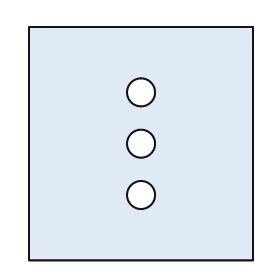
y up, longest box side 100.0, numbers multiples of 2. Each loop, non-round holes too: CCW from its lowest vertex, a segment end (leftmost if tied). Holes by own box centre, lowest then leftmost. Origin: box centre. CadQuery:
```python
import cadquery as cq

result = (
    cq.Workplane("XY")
    .moveTo(-48.0, -50.0)
    .lineTo(48.0, -50.0)
    .lineTo(48.0, 50.0)
    .lineTo(-48.0, 50.0)
    .close()
    .moveTo(0.0, -22.0)
    .circle(6.0)
    .moveTo(0.0, 0.0)
    .circle(6.0)
    .moveTo(0.0, 22.0)
    .circle(6.0)
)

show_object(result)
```